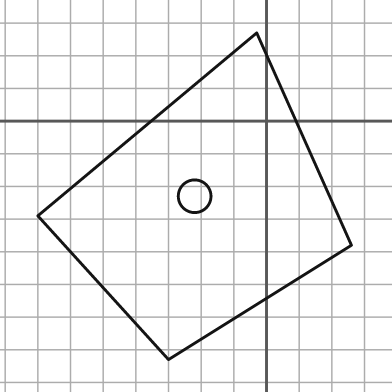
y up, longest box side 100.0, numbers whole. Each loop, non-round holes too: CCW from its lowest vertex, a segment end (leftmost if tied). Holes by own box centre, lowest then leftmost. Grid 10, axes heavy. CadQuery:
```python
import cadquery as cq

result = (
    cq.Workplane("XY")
    .moveTo(-30.0, -73.0)
    .lineTo(26.0, -38.0)
    .lineTo(-3.0, 27.0)
    .lineTo(-70.0, -29.0)
    .close()
    .moveTo(-22.0, -23.0)
    .circle(5.0)
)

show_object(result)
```